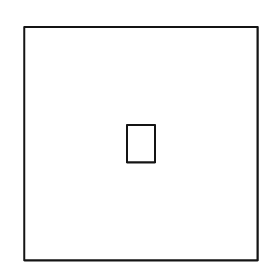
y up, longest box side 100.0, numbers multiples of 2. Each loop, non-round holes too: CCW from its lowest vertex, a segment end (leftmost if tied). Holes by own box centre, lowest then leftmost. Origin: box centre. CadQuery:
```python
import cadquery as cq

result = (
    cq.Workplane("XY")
    .moveTo(-50.0, -50.0)
    .lineTo(50.0, -50.0)
    .lineTo(50.0, 50.0)
    .lineTo(-50.0, 50.0)
    .close()
    .moveTo(-6.0, -8.0)
    .lineTo(6.0, -8.0)
    .lineTo(6.0, 8.0)
    .lineTo(-6.0, 8.0)
    .close()
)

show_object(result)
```